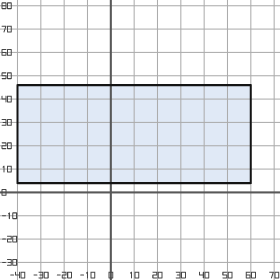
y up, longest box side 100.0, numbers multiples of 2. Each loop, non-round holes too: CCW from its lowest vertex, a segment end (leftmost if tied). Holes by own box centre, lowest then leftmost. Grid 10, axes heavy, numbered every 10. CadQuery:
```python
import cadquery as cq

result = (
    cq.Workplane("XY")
    .moveTo(-40.0, 4.0)
    .lineTo(60.0, 4.0)
    .lineTo(60.0, 46.0)
    .lineTo(-40.0, 46.0)
    .close()
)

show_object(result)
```